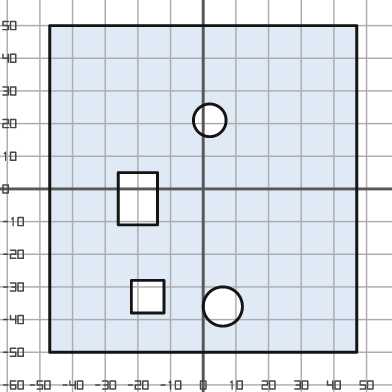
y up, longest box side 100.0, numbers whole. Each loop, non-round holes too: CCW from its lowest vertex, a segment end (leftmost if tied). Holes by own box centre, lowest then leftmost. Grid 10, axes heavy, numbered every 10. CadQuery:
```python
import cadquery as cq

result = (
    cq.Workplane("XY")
    .moveTo(-47.0, -50.0)
    .lineTo(47.0, -50.0)
    .lineTo(47.0, 50.0)
    .lineTo(-47.0, 50.0)
    .close()
    .moveTo(6.0, -36.0)
    .circle(6.0)
    .moveTo(-22.0, -38.0)
    .lineTo(-12.0, -38.0)
    .lineTo(-12.0, -28.0)
    .lineTo(-22.0, -28.0)
    .close()
    .moveTo(-26.0, -11.0)
    .lineTo(-14.0, -11.0)
    .lineTo(-14.0, 5.0)
    .lineTo(-26.0, 5.0)
    .close()
    .moveTo(2.0, 21.0)
    .circle(5.0)
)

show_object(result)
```